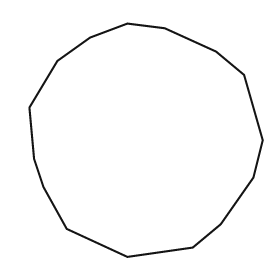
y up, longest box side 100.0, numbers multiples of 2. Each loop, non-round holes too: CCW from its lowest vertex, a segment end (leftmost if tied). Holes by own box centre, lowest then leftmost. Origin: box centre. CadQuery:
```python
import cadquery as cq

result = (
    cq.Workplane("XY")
    .moveTo(-8.0, -50.0)
    .lineTo(20.0, -46.0)
    .lineTo(32.0, -36.0)
    .lineTo(46.0, -16.0)
    .lineTo(50.0, 0.0)
    .lineTo(42.0, 28.0)
    .lineTo(30.0, 38.0)
    .lineTo(8.0, 48.0)
    .lineTo(-8.0, 50.0)
    .lineTo(-24.0, 44.0)
    .lineTo(-38.0, 34.0)
    .lineTo(-50.0, 14.0)
    .lineTo(-48.0, -8.0)
    .lineTo(-44.0, -20.0)
    .lineTo(-34.0, -38.0)
    .close()
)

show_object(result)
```